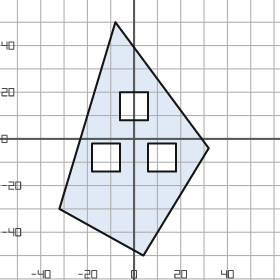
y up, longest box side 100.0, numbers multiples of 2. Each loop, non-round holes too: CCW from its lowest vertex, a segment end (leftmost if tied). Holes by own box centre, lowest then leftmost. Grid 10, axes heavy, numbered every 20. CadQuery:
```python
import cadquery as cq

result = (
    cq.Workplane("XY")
    .moveTo(4.0, -50.0)
    .lineTo(32.0, -4.0)
    .lineTo(-8.0, 50.0)
    .lineTo(-32.0, -30.0)
    .close()
    .moveTo(-18.0, -14.0)
    .lineTo(-6.0, -14.0)
    .lineTo(-6.0, -2.0)
    .lineTo(-18.0, -2.0)
    .close()
    .moveTo(6.0, -14.0)
    .lineTo(18.0, -14.0)
    .lineTo(18.0, -2.0)
    .lineTo(6.0, -2.0)
    .close()
    .moveTo(-6.0, 8.0)
    .lineTo(6.0, 8.0)
    .lineTo(6.0, 20.0)
    .lineTo(-6.0, 20.0)
    .close()
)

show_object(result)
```